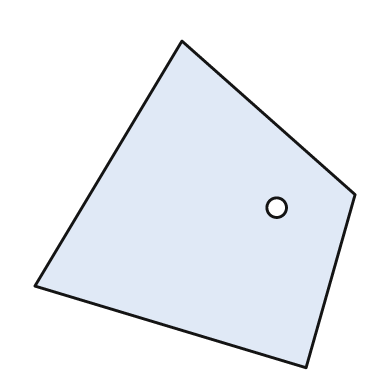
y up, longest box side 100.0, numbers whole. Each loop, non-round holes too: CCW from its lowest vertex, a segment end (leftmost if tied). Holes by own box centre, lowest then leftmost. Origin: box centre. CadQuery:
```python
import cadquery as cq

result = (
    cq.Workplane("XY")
    .moveTo(34.0, -50.0)
    .lineTo(49.0, 3.0)
    .lineTo(-4.0, 50.0)
    .lineTo(-49.0, -25.0)
    .close()
    .moveTo(25.0, -1.0)
    .circle(3.0)
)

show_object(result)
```